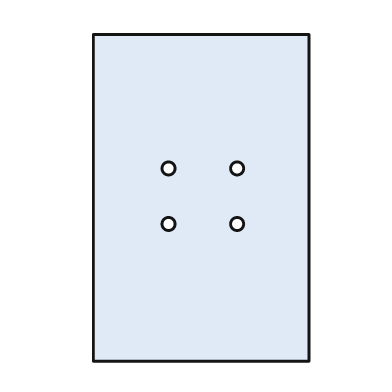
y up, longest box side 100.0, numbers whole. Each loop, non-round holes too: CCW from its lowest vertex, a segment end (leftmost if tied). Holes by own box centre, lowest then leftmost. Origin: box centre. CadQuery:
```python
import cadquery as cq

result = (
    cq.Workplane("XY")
    .moveTo(-33.0, -50.0)
    .lineTo(33.0, -50.0)
    .lineTo(33.0, 50.0)
    .lineTo(-33.0, 50.0)
    .close()
    .moveTo(-10.0, -8.0)
    .circle(2.0)
    .moveTo(11.0, -8.0)
    .circle(2.0)
    .moveTo(-10.0, 9.0)
    .circle(2.0)
    .moveTo(11.0, 9.0)
    .circle(2.0)
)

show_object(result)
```